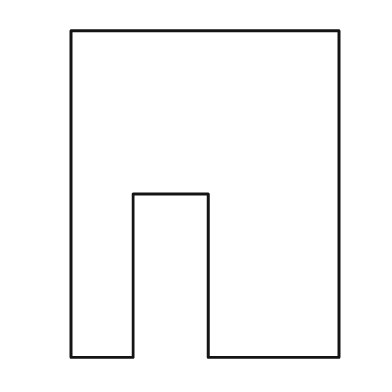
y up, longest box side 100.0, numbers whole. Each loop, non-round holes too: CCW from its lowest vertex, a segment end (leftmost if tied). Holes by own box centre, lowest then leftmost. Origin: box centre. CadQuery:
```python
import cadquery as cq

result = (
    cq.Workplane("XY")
    .moveTo(-41.0, -50.0)
    .lineTo(-22.0, -50.0)
    .lineTo(-22.0, 0.0)
    .lineTo(1.0, 0.0)
    .lineTo(1.0, -50.0)
    .lineTo(41.0, -50.0)
    .lineTo(41.0, 50.0)
    .lineTo(-41.0, 50.0)
    .close()
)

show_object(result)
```